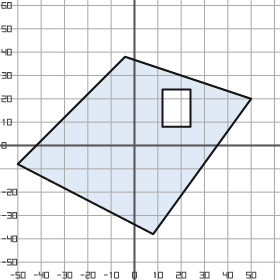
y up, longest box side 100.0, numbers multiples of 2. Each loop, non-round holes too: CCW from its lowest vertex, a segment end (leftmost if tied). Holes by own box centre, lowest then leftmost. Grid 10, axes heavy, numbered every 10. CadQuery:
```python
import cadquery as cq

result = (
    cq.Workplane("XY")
    .moveTo(8.0, -38.0)
    .lineTo(50.0, 20.0)
    .lineTo(-4.0, 38.0)
    .lineTo(-50.0, -8.0)
    .close()
    .moveTo(12.0, 8.0)
    .lineTo(24.0, 8.0)
    .lineTo(24.0, 24.0)
    .lineTo(12.0, 24.0)
    .close()
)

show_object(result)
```